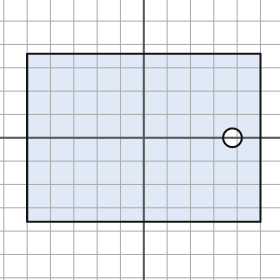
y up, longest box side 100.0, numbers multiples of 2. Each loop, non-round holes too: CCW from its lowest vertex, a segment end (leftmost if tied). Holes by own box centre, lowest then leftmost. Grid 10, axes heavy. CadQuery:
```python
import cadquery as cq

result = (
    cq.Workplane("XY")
    .moveTo(-50.0, -36.0)
    .lineTo(50.0, -36.0)
    .lineTo(50.0, 36.0)
    .lineTo(-50.0, 36.0)
    .close()
    .moveTo(38.0, 0.0)
    .circle(4.0)
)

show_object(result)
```